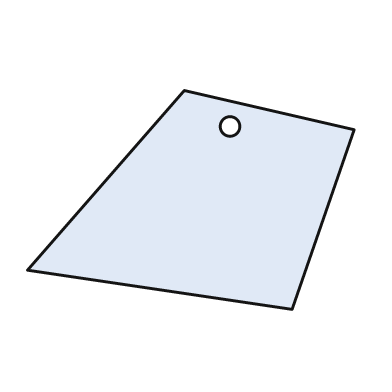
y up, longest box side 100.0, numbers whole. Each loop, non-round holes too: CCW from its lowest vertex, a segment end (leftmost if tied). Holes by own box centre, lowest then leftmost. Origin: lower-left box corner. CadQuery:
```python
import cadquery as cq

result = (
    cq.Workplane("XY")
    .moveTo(81.0, 0.0)
    .lineTo(100.0, 55.0)
    .lineTo(48.0, 67.0)
    .lineTo(0.0, 12.0)
    .close()
    .moveTo(62.0, 56.0)
    .circle(3.0)
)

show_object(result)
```